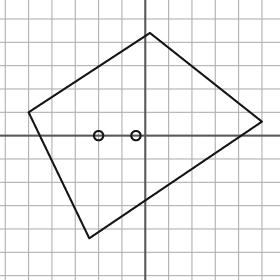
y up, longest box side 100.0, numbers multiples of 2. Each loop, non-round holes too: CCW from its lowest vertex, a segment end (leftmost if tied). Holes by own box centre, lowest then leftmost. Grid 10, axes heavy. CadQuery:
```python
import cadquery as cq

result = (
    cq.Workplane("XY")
    .moveTo(-24.0, -44.0)
    .lineTo(50.0, 6.0)
    .lineTo(2.0, 44.0)
    .lineTo(-50.0, 10.0)
    .close()
    .moveTo(-20.0, 0.0)
    .circle(2.0)
    .moveTo(-4.0, 0.0)
    .circle(2.0)
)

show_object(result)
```